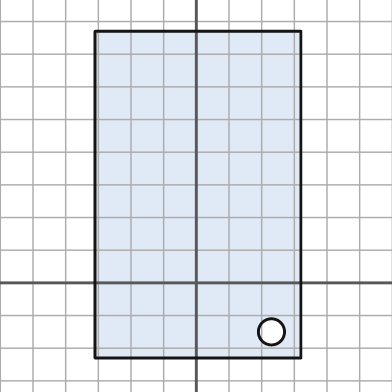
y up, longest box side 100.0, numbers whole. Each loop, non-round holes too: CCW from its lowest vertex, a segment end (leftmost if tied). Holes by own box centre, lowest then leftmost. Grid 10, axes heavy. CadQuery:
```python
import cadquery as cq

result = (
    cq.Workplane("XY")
    .moveTo(-31.0, -23.0)
    .lineTo(32.0, -23.0)
    .lineTo(32.0, 77.0)
    .lineTo(-31.0, 77.0)
    .close()
    .moveTo(23.0, -15.0)
    .circle(4.0)
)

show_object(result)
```